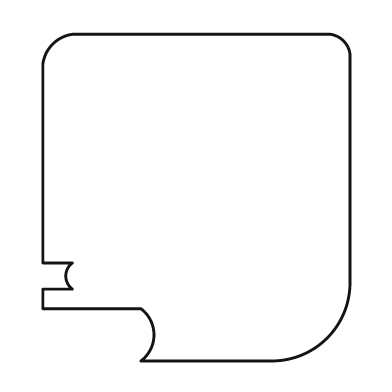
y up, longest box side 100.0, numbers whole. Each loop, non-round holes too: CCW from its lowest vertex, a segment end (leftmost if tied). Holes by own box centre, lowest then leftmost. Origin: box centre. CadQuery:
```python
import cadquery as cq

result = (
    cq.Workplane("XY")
    .moveTo(-17.0, -50.0)
    .lineTo(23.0, -50.0)
    .threePointArc((40.0, -43.0), (47.0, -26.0))
    .lineTo(47.0, 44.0)
    .threePointArc((45.0, 48.0), (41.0, 50.0))
    .lineTo(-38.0, 50.0)
    .threePointArc((-44.0, 47.0), (-47.0, 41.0))
    .lineTo(-47.0, -20.0)
    .lineTo(-38.0, -20.0)
    .threePointArc((-40.0, -24.0), (-38.0, -28.0))
    .lineTo(-47.0, -28.0)
    .lineTo(-47.0, -34.0)
    .lineTo(-17.0, -34.0)
    .threePointArc((-13.0, -42.0), (-17.0, -50.0))
    .close()
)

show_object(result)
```